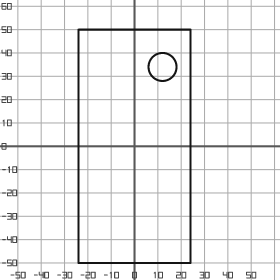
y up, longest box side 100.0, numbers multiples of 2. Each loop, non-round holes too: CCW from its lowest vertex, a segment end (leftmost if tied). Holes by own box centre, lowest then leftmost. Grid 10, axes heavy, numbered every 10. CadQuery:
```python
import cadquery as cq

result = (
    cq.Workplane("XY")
    .moveTo(-24.0, -50.0)
    .lineTo(24.0, -50.0)
    .lineTo(24.0, 50.0)
    .lineTo(-24.0, 50.0)
    .close()
    .moveTo(12.0, 34.0)
    .circle(6.0)
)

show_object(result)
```